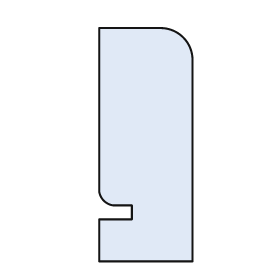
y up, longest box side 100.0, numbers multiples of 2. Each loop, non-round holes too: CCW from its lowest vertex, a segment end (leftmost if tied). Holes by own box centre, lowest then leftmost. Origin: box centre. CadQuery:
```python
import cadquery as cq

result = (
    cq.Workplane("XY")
    .moveTo(-20.0, -50.0)
    .lineTo(20.0, -50.0)
    .lineTo(20.0, 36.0)
    .threePointArc((16.0, 46.0), (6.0, 50.0))
    .lineTo(-20.0, 50.0)
    .lineTo(-20.0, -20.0)
    .threePointArc((-18.0, -24.0), (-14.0, -26.0))
    .lineTo(-6.0, -26.0)
    .lineTo(-6.0, -32.0)
    .lineTo(-20.0, -32.0)
    .close()
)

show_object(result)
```